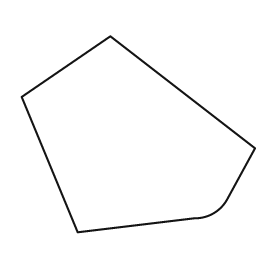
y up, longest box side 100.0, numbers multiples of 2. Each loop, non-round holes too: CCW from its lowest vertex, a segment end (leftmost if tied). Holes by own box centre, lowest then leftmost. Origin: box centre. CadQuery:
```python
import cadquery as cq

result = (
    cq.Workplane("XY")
    .moveTo(-26.0, -42.0)
    .lineTo(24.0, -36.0)
    .threePointArc((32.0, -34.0), (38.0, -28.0))
    .lineTo(50.0, -6.0)
    .lineTo(-12.0, 42.0)
    .lineTo(-50.0, 16.0)
    .close()
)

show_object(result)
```